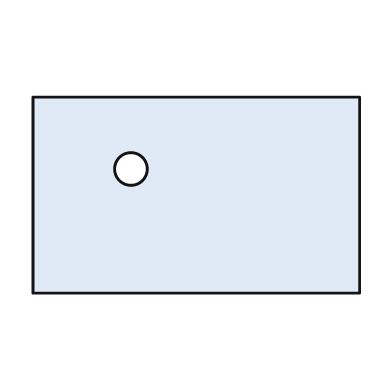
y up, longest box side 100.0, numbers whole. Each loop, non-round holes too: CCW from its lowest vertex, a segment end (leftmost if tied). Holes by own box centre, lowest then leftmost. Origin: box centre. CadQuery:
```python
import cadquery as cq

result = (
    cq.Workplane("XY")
    .moveTo(-50.0, -30.0)
    .lineTo(50.0, -30.0)
    .lineTo(50.0, 30.0)
    .lineTo(-50.0, 30.0)
    .close()
    .moveTo(-20.0, 8.0)
    .circle(5.0)
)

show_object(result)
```